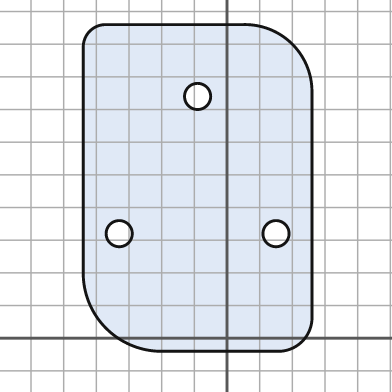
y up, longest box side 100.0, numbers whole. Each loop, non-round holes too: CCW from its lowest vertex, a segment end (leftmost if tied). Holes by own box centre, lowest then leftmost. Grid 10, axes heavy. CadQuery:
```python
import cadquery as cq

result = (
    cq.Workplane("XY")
    .moveTo(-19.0, -4.0)
    .lineTo(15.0, -4.0)
    .threePointArc((23.0, -1.0), (26.0, 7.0))
    .lineTo(26.0, 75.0)
    .threePointArc((20.0, 90.0), (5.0, 96.0))
    .lineTo(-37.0, 96.0)
    .threePointArc((-42.0, 94.0), (-44.0, 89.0))
    .lineTo(-44.0, 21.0)
    .threePointArc((-37.0, 3.0), (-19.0, -4.0))
    .close()
    .moveTo(-33.0, 32.0)
    .circle(4.0)
    .moveTo(15.0, 32.0)
    .circle(4.0)
    .moveTo(-9.0, 74.0)
    .circle(4.0)
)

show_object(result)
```